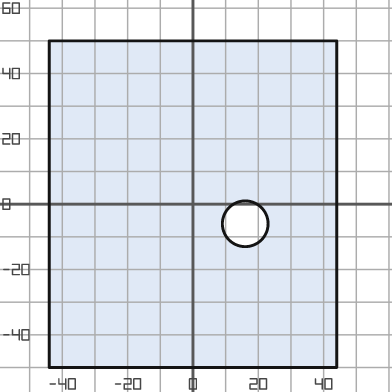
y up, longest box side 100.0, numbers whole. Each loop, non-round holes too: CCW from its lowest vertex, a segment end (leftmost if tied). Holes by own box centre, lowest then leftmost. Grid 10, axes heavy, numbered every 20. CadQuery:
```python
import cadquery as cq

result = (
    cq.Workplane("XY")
    .moveTo(-44.0, -50.0)
    .lineTo(44.0, -50.0)
    .lineTo(44.0, 50.0)
    .lineTo(-44.0, 50.0)
    .close()
    .moveTo(16.0, -6.0)
    .circle(7.0)
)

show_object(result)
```